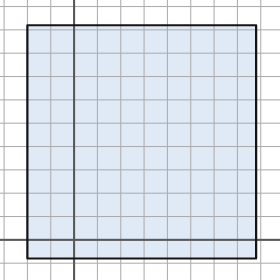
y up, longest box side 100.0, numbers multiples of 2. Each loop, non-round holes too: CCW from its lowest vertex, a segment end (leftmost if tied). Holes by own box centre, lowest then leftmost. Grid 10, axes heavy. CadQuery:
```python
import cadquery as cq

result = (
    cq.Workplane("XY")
    .moveTo(-20.0, -8.0)
    .lineTo(78.0, -8.0)
    .lineTo(78.0, 92.0)
    .lineTo(-20.0, 92.0)
    .close()
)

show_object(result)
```